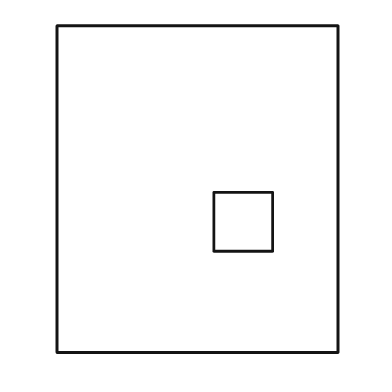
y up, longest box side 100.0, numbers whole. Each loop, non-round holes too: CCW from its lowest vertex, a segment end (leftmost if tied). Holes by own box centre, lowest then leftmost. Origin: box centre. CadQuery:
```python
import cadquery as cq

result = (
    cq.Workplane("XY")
    .moveTo(-43.0, -50.0)
    .lineTo(43.0, -50.0)
    .lineTo(43.0, 50.0)
    .lineTo(-43.0, 50.0)
    .close()
    .moveTo(5.0, -19.0)
    .lineTo(23.0, -19.0)
    .lineTo(23.0, -1.0)
    .lineTo(5.0, -1.0)
    .close()
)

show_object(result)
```